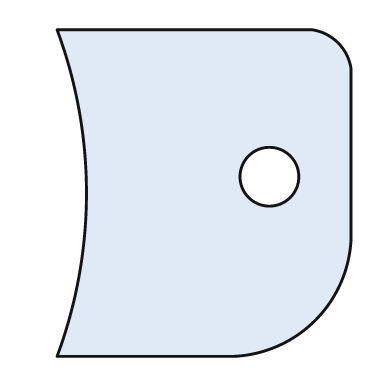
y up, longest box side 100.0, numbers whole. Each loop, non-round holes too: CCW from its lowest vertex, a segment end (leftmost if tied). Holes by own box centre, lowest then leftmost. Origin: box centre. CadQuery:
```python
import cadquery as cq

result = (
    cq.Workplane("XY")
    .moveTo(-45.0, -50.0)
    .lineTo(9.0, -50.0)
    .threePointArc((34.0, -39.0), (45.0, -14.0))
    .lineTo(45.0, 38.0)
    .threePointArc((41.0, 46.0), (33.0, 50.0))
    .lineTo(-45.0, 50.0)
    .threePointArc((-36.0, 0.0), (-45.0, -50.0))
    .close()
    .moveTo(20.0, 5.0)
    .circle(9.0)
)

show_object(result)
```